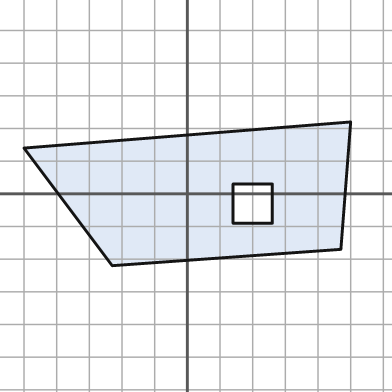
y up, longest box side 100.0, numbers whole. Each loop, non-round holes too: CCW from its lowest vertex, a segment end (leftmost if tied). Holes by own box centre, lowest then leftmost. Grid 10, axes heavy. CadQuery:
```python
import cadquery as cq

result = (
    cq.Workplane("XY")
    .moveTo(-23.0, -22.0)
    .lineTo(47.0, -17.0)
    .lineTo(50.0, 22.0)
    .lineTo(-50.0, 14.0)
    .close()
    .moveTo(14.0, -9.0)
    .lineTo(26.0, -9.0)
    .lineTo(26.0, 3.0)
    .lineTo(14.0, 3.0)
    .close()
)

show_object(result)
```